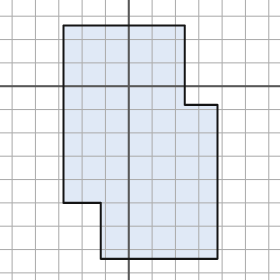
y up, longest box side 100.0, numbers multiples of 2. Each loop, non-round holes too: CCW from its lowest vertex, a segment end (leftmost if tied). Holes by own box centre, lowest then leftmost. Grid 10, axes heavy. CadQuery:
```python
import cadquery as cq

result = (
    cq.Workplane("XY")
    .moveTo(-12.0, -74.0)
    .lineTo(38.0, -74.0)
    .lineTo(38.0, -8.0)
    .lineTo(24.0, -8.0)
    .lineTo(24.0, 26.0)
    .lineTo(-28.0, 26.0)
    .lineTo(-28.0, -50.0)
    .lineTo(-12.0, -50.0)
    .close()
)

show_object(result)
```